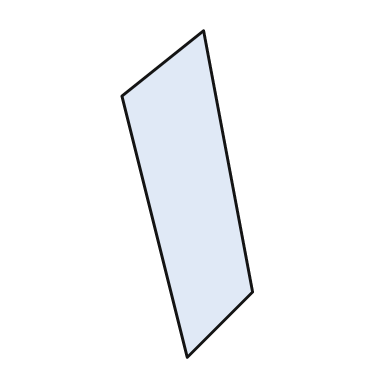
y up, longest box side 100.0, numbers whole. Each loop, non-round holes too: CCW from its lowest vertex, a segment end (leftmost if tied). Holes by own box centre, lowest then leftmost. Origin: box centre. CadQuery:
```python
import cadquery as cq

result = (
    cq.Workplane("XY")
    .moveTo(0.0, -50.0)
    .lineTo(20.0, -30.0)
    .lineTo(5.0, 50.0)
    .lineTo(-20.0, 30.0)
    .close()
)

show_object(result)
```